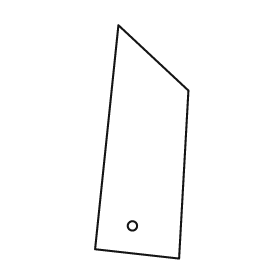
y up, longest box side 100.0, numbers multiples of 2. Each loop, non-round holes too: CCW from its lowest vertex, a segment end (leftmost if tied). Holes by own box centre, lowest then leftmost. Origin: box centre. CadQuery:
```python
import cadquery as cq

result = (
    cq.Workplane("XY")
    .moveTo(16.0, -50.0)
    .lineTo(20.0, 22.0)
    .lineTo(-10.0, 50.0)
    .lineTo(-20.0, -46.0)
    .close()
    .moveTo(-4.0, -36.0)
    .circle(2.0)
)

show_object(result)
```